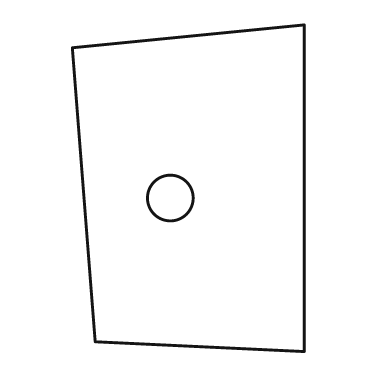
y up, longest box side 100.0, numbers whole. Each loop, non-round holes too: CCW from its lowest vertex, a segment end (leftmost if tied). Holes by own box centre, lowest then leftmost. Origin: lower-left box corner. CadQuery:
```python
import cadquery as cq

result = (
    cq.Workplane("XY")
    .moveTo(71.0, 0.0)
    .lineTo(71.0, 100.0)
    .lineTo(0.0, 93.0)
    .lineTo(7.0, 3.0)
    .close()
    .moveTo(30.0, 47.0)
    .circle(7.0)
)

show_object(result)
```